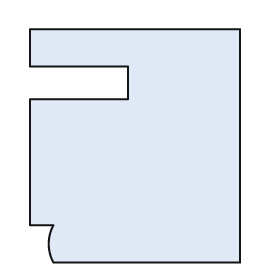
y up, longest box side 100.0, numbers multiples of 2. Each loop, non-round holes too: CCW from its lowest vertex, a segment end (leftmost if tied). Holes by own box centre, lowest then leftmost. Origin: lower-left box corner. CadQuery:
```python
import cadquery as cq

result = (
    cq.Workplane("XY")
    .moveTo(10.0, 0.0)
    .lineTo(90.0, 0.0)
    .lineTo(90.0, 100.0)
    .lineTo(0.0, 100.0)
    .lineTo(0.0, 84.0)
    .lineTo(42.0, 84.0)
    .lineTo(42.0, 70.0)
    .lineTo(0.0, 70.0)
    .lineTo(0.0, 16.0)
    .lineTo(10.0, 16.0)
    .threePointArc((8.0, 8.0), (10.0, 0.0))
    .close()
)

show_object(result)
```